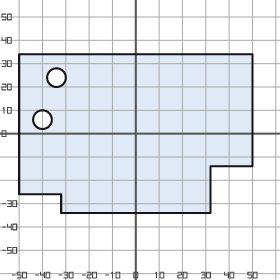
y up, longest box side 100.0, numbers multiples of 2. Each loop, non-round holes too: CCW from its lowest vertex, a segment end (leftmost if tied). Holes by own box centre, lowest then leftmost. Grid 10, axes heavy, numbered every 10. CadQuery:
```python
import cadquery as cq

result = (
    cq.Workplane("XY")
    .moveTo(-32.0, -34.0)
    .lineTo(32.0, -34.0)
    .lineTo(32.0, -14.0)
    .lineTo(50.0, -14.0)
    .lineTo(50.0, 34.0)
    .lineTo(-50.0, 34.0)
    .lineTo(-50.0, -26.0)
    .lineTo(-32.0, -26.0)
    .close()
    .moveTo(-40.0, 6.0)
    .circle(4.0)
    .moveTo(-34.0, 24.0)
    .circle(4.0)
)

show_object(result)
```